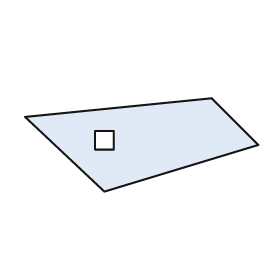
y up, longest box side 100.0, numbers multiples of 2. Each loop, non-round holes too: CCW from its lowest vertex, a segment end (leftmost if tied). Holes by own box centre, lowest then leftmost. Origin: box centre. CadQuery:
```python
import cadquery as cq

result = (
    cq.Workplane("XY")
    .moveTo(-16.0, -20.0)
    .lineTo(50.0, 0.0)
    .lineTo(30.0, 20.0)
    .lineTo(-50.0, 12.0)
    .close()
    .moveTo(-20.0, -2.0)
    .lineTo(-12.0, -2.0)
    .lineTo(-12.0, 6.0)
    .lineTo(-20.0, 6.0)
    .close()
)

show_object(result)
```